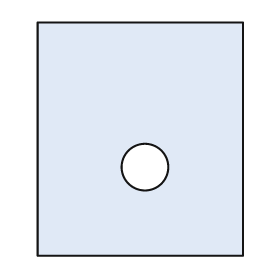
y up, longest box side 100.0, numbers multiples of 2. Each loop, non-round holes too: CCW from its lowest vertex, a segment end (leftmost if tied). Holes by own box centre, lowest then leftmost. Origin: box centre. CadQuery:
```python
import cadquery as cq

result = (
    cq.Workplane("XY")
    .moveTo(-44.0, -50.0)
    .lineTo(44.0, -50.0)
    .lineTo(44.0, 50.0)
    .lineTo(-44.0, 50.0)
    .close()
    .moveTo(2.0, -12.0)
    .circle(10.0)
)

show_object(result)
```